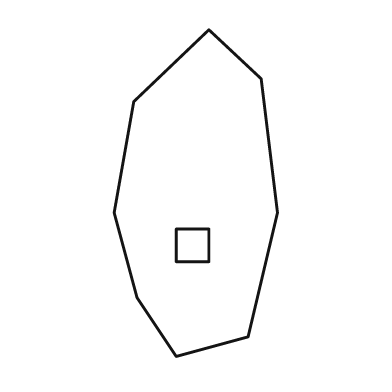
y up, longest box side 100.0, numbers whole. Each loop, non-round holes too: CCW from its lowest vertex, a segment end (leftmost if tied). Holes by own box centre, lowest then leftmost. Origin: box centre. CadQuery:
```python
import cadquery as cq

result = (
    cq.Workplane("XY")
    .moveTo(-6.0, -50.0)
    .lineTo(16.0, -44.0)
    .lineTo(25.0, -6.0)
    .lineTo(20.0, 35.0)
    .lineTo(4.0, 50.0)
    .lineTo(-19.0, 28.0)
    .lineTo(-25.0, -6.0)
    .lineTo(-18.0, -32.0)
    .close()
    .moveTo(-6.0, -21.0)
    .lineTo(4.0, -21.0)
    .lineTo(4.0, -11.0)
    .lineTo(-6.0, -11.0)
    .close()
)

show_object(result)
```